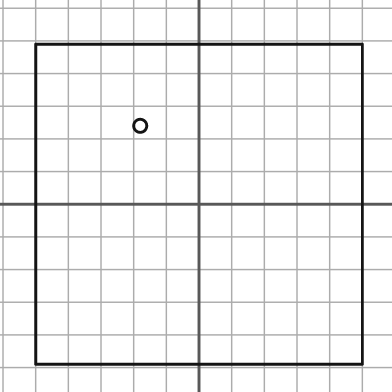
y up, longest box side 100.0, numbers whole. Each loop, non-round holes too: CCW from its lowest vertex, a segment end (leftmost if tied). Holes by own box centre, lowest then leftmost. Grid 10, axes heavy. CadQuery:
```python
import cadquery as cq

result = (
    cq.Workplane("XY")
    .moveTo(-50.0, -49.0)
    .lineTo(50.0, -49.0)
    .lineTo(50.0, 49.0)
    .lineTo(-50.0, 49.0)
    .close()
    .moveTo(-18.0, 24.0)
    .circle(2.0)
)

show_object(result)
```